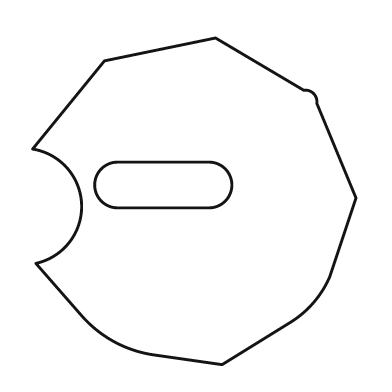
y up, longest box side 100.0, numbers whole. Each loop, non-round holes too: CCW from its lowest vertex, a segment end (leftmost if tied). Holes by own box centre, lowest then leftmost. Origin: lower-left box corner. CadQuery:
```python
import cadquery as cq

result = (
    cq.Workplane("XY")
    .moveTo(58.0, 0.0)
    .lineTo(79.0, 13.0)
    .threePointArc((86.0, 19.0), (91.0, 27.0))
    .lineTo(99.0, 51.0)
    .lineTo(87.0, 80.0)
    .threePointArc((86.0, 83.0), (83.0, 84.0))
    .lineTo(56.0, 100.0)
    .lineTo(22.0, 93.0)
    .lineTo(0.0, 66.0)
    .threePointArc((15.0, 49.0), (1.0, 31.0))
    .lineTo(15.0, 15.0)
    .threePointArc((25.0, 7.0), (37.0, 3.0))
    .close()
    .moveTo(26.0, 48.0)
    .lineTo(54.0, 48.0)
    .threePointArc((61.0, 55.0), (54.0, 62.0))
    .lineTo(26.0, 62.0)
    .threePointArc((19.0, 55.0), (26.0, 48.0))
    .close()
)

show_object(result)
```